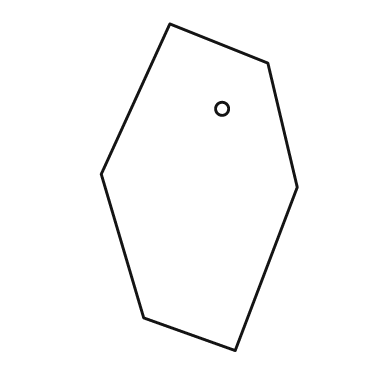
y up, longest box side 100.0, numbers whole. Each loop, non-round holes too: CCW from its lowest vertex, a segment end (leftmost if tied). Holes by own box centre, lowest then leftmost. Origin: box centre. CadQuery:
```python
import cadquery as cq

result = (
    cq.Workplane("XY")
    .moveTo(11.0, -50.0)
    .lineTo(30.0, 0.0)
    .lineTo(21.0, 38.0)
    .lineTo(-9.0, 50.0)
    .lineTo(-30.0, 4.0)
    .lineTo(-17.0, -40.0)
    .close()
    .moveTo(7.0, 24.0)
    .circle(2.0)
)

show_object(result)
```